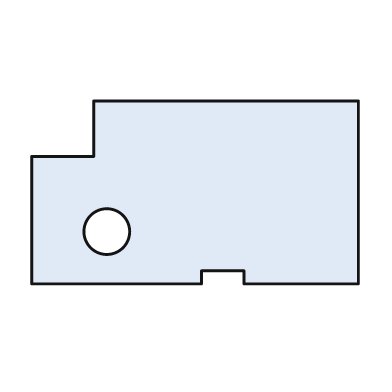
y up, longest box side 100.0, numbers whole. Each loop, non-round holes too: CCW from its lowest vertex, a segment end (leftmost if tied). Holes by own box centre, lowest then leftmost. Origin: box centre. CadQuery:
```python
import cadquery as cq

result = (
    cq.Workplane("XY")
    .moveTo(-50.0, -28.0)
    .lineTo(2.0, -28.0)
    .lineTo(2.0, -24.0)
    .lineTo(15.0, -24.0)
    .lineTo(15.0, -28.0)
    .lineTo(50.0, -28.0)
    .lineTo(50.0, 28.0)
    .lineTo(-31.0, 28.0)
    .lineTo(-31.0, 11.0)
    .lineTo(-50.0, 11.0)
    .close()
    .moveTo(-27.0, -12.0)
    .circle(7.0)
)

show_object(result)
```